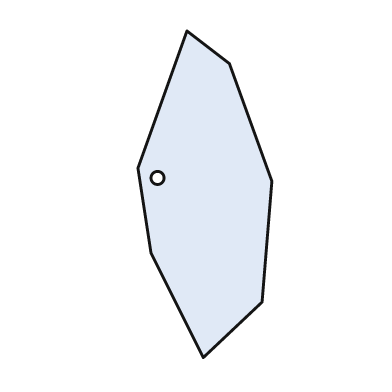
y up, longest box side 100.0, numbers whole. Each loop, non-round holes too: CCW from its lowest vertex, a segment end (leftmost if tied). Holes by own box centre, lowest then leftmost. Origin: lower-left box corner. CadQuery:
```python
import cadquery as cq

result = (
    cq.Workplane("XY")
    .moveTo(20.0, 0.0)
    .lineTo(38.0, 17.0)
    .lineTo(41.0, 54.0)
    .lineTo(28.0, 90.0)
    .lineTo(15.0, 100.0)
    .lineTo(0.0, 58.0)
    .lineTo(4.0, 32.0)
    .close()
    .moveTo(6.0, 55.0)
    .circle(2.0)
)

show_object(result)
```